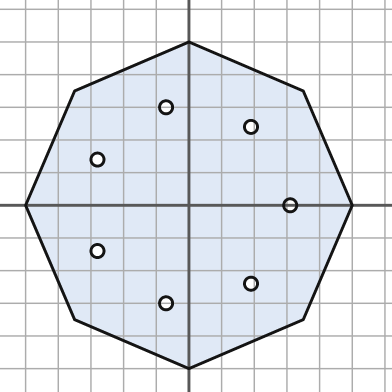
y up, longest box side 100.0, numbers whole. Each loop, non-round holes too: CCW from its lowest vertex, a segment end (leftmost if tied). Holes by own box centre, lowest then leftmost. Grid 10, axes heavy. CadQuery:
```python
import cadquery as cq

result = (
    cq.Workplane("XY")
    .moveTo(0.0, -50.0)
    .lineTo(35.0, -35.0)
    .lineTo(50.0, 0.0)
    .lineTo(35.0, 35.0)
    .lineTo(0.0, 50.0)
    .lineTo(-35.0, 35.0)
    .lineTo(-50.0, 0.0)
    .lineTo(-35.0, -35.0)
    .close()
    .moveTo(-7.0, -30.0)
    .circle(2.0)
    .moveTo(19.0, -24.0)
    .circle(2.0)
    .moveTo(-28.0, -14.0)
    .circle(2.0)
    .moveTo(31.0, 0.0)
    .circle(2.0)
    .moveTo(-28.0, 14.0)
    .circle(2.0)
    .moveTo(19.0, 24.0)
    .circle(2.0)
    .moveTo(-7.0, 30.0)
    .circle(2.0)
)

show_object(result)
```